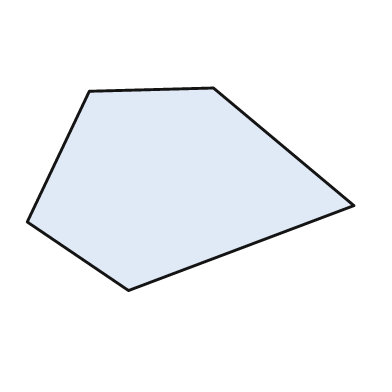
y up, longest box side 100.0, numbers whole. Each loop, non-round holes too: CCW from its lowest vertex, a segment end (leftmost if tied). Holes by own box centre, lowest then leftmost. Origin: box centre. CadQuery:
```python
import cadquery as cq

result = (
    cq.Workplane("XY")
    .moveTo(-19.0, -31.0)
    .lineTo(50.0, -5.0)
    .lineTo(7.0, 31.0)
    .lineTo(-31.0, 30.0)
    .lineTo(-50.0, -10.0)
    .close()
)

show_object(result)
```